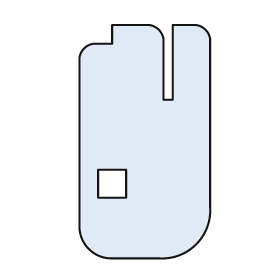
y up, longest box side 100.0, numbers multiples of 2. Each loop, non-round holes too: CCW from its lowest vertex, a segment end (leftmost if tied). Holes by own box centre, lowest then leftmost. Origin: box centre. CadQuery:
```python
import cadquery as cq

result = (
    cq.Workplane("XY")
    .moveTo(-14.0, -50.0)
    .lineTo(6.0, -50.0)
    .threePointArc((22.0, -44.0), (28.0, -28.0))
    .lineTo(28.0, 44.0)
    .threePointArc((26.0, 48.0), (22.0, 50.0))
    .lineTo(12.0, 50.0)
    .lineTo(12.0, 18.0)
    .lineTo(8.0, 18.0)
    .lineTo(8.0, 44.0)
    .threePointArc((6.0, 48.0), (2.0, 50.0))
    .lineTo(-14.0, 50.0)
    .lineTo(-14.0, 42.0)
    .lineTo(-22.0, 42.0)
    .threePointArc((-26.0, 40.0), (-28.0, 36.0))
    .lineTo(-28.0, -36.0)
    .threePointArc((-24.0, -46.0), (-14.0, -50.0))
    .close()
    .moveTo(-20.0, -24.0)
    .lineTo(-8.0, -24.0)
    .lineTo(-8.0, -12.0)
    .lineTo(-20.0, -12.0)
    .close()
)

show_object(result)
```